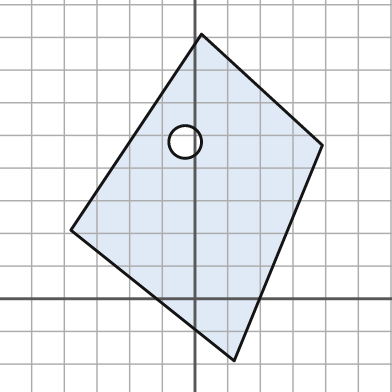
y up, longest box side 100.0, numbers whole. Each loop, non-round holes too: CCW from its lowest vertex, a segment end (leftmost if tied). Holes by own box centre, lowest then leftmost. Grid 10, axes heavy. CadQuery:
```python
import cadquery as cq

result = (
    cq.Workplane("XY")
    .moveTo(12.0, -19.0)
    .lineTo(39.0, 47.0)
    .lineTo(2.0, 81.0)
    .lineTo(-38.0, 21.0)
    .close()
    .moveTo(-3.0, 48.0)
    .circle(5.0)
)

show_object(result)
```